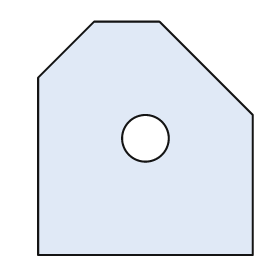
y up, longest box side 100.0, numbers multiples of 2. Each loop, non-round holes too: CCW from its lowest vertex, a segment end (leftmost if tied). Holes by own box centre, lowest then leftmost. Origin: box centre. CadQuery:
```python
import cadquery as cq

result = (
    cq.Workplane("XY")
    .moveTo(-46.0, -50.0)
    .lineTo(46.0, -50.0)
    .lineTo(46.0, 10.0)
    .lineTo(6.0, 50.0)
    .lineTo(-22.0, 50.0)
    .lineTo(-46.0, 26.0)
    .close()
    .moveTo(0.0, 0.0)
    .circle(10.0)
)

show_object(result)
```